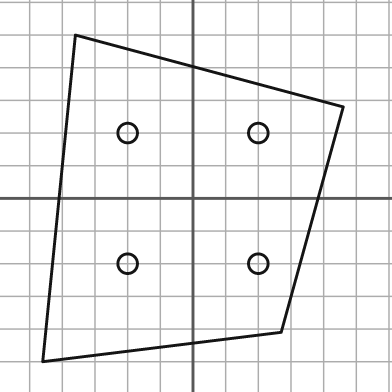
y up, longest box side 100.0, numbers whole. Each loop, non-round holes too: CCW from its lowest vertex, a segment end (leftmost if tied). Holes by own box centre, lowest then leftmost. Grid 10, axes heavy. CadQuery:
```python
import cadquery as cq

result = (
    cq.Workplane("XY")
    .moveTo(-46.0, -50.0)
    .lineTo(27.0, -41.0)
    .lineTo(46.0, 28.0)
    .lineTo(-36.0, 50.0)
    .close()
    .moveTo(-20.0, -20.0)
    .circle(3.0)
    .moveTo(20.0, -20.0)
    .circle(3.0)
    .moveTo(-20.0, 20.0)
    .circle(3.0)
    .moveTo(20.0, 20.0)
    .circle(3.0)
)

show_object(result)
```